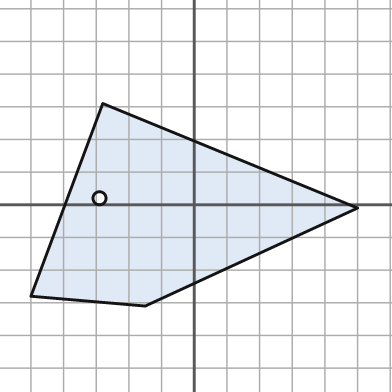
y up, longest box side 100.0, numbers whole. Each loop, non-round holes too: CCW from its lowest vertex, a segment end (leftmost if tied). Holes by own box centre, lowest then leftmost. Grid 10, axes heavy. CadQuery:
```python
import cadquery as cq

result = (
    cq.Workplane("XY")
    .moveTo(-15.0, -31.0)
    .lineTo(50.0, -1.0)
    .lineTo(-28.0, 31.0)
    .lineTo(-50.0, -28.0)
    .close()
    .moveTo(-29.0, 2.0)
    .circle(2.0)
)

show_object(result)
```